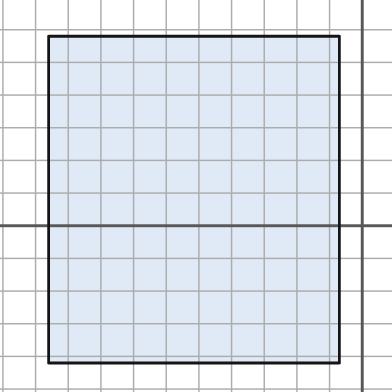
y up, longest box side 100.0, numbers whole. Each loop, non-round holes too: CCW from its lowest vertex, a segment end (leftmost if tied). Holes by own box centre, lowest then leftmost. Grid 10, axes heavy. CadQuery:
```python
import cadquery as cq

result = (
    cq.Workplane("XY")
    .moveTo(-96.0, -42.0)
    .lineTo(-7.0, -42.0)
    .lineTo(-7.0, 58.0)
    .lineTo(-96.0, 58.0)
    .close()
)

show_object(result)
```